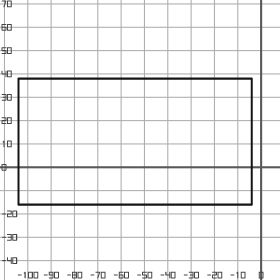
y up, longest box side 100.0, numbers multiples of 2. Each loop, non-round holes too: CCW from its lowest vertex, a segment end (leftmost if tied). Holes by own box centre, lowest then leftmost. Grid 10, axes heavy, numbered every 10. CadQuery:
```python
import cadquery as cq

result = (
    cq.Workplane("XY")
    .moveTo(-104.0, -16.0)
    .lineTo(-4.0, -16.0)
    .lineTo(-4.0, 38.0)
    .lineTo(-104.0, 38.0)
    .close()
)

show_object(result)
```